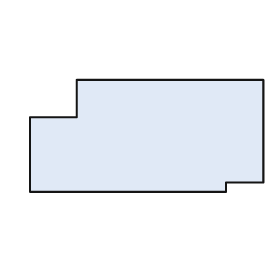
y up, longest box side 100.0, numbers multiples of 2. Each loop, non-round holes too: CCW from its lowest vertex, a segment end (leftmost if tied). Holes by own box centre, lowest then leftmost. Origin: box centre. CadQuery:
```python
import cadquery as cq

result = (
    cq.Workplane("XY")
    .moveTo(-50.0, -24.0)
    .lineTo(34.0, -24.0)
    .lineTo(34.0, -20.0)
    .lineTo(50.0, -20.0)
    .lineTo(50.0, 24.0)
    .lineTo(-30.0, 24.0)
    .lineTo(-30.0, 8.0)
    .lineTo(-50.0, 8.0)
    .close()
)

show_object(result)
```